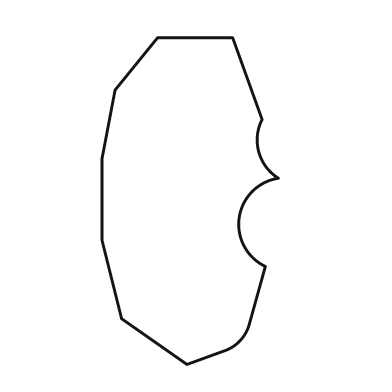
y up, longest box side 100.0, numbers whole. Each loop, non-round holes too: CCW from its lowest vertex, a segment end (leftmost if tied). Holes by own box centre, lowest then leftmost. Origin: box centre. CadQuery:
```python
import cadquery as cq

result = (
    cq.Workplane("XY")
    .moveTo(-1.0, -50.0)
    .lineTo(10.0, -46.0)
    .threePointArc((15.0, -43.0), (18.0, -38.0))
    .lineTo(23.0, -20.0)
    .threePointArc((15.0, -5.0), (27.0, 7.0))
    .threePointArc((21.0, 15.0), (22.0, 25.0))
    .lineTo(13.0, 50.0)
    .lineTo(-10.0, 50.0)
    .lineTo(-23.0, 34.0)
    .lineTo(-27.0, 13.0)
    .lineTo(-27.0, -12.0)
    .lineTo(-21.0, -36.0)
    .close()
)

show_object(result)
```